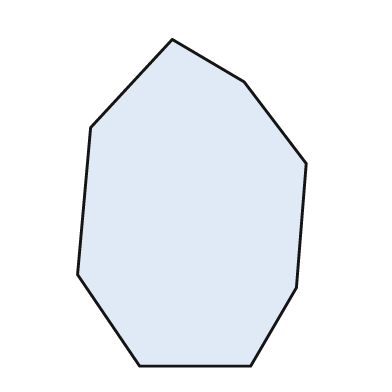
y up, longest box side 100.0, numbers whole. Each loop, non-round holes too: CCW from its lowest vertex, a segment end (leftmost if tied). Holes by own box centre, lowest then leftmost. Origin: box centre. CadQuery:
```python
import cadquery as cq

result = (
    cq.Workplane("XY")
    .moveTo(-16.0, -50.0)
    .lineTo(18.0, -50.0)
    .lineTo(32.0, -26.0)
    .lineTo(35.0, 12.0)
    .lineTo(16.0, 37.0)
    .lineTo(-6.0, 50.0)
    .lineTo(-31.0, 23.0)
    .lineTo(-35.0, -22.0)
    .close()
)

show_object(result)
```